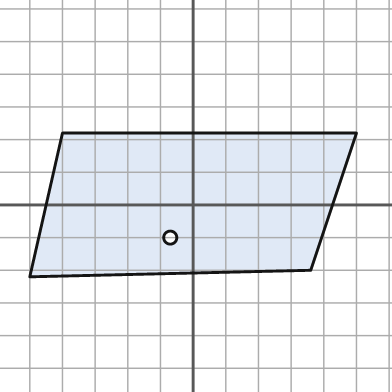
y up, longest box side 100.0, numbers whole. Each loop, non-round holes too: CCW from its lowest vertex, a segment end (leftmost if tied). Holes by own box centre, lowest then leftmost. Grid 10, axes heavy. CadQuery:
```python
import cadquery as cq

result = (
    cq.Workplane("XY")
    .moveTo(-50.0, -22.0)
    .lineTo(36.0, -20.0)
    .lineTo(50.0, 22.0)
    .lineTo(-40.0, 22.0)
    .close()
    .moveTo(-7.0, -10.0)
    .circle(2.0)
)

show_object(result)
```